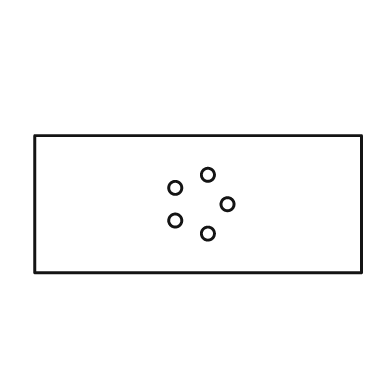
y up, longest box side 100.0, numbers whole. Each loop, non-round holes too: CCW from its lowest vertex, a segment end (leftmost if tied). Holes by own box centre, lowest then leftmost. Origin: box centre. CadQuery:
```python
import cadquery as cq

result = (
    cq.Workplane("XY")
    .moveTo(-50.0, -21.0)
    .lineTo(50.0, -21.0)
    .lineTo(50.0, 21.0)
    .lineTo(-50.0, 21.0)
    .close()
    .moveTo(3.0, -9.0)
    .circle(2.0)
    .moveTo(-7.0, -5.0)
    .circle(2.0)
    .moveTo(9.0, 0.0)
    .circle(2.0)
    .moveTo(-7.0, 5.0)
    .circle(2.0)
    .moveTo(3.0, 9.0)
    .circle(2.0)
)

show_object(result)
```